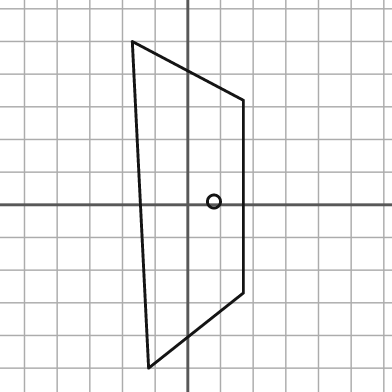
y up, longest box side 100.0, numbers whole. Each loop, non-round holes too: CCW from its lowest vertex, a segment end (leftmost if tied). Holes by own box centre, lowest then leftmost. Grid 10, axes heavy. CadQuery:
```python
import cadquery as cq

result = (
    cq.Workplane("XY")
    .moveTo(-12.0, -50.0)
    .lineTo(17.0, -27.0)
    .lineTo(17.0, 32.0)
    .lineTo(-17.0, 50.0)
    .close()
    .moveTo(8.0, 1.0)
    .circle(2.0)
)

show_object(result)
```